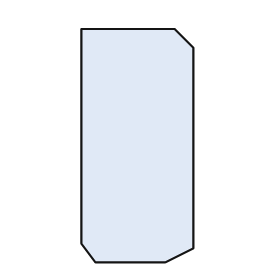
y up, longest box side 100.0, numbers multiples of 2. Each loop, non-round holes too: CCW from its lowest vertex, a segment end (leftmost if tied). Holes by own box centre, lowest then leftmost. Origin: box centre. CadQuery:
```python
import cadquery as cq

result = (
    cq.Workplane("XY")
    .moveTo(-18.0, -50.0)
    .lineTo(12.0, -50.0)
    .lineTo(24.0, -44.0)
    .lineTo(24.0, 42.0)
    .lineTo(16.0, 50.0)
    .lineTo(-24.0, 50.0)
    .lineTo(-24.0, -42.0)
    .close()
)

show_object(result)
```